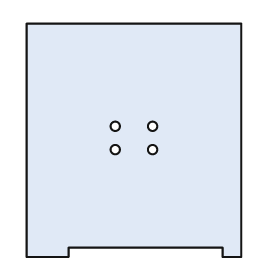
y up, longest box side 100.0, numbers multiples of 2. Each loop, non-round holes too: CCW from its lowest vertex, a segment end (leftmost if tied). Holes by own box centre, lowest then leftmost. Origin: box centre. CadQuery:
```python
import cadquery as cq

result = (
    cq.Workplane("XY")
    .moveTo(-46.0, -50.0)
    .lineTo(-28.0, -50.0)
    .lineTo(-28.0, -46.0)
    .lineTo(38.0, -46.0)
    .lineTo(38.0, -50.0)
    .lineTo(46.0, -50.0)
    .lineTo(46.0, 50.0)
    .lineTo(-46.0, 50.0)
    .close()
    .moveTo(-8.0, -4.0)
    .circle(2.0)
    .moveTo(8.0, -4.0)
    .circle(2.0)
    .moveTo(-8.0, 6.0)
    .circle(2.0)
    .moveTo(8.0, 6.0)
    .circle(2.0)
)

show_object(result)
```